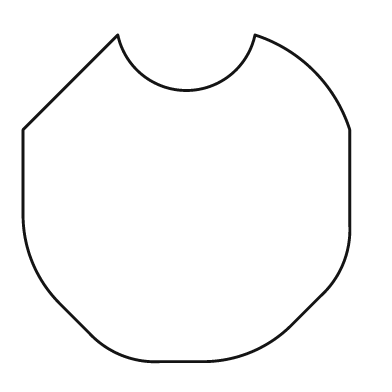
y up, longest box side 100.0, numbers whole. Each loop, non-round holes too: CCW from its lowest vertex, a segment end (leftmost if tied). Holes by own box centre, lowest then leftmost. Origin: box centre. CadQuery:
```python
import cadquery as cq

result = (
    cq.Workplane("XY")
    .moveTo(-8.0, -50.0)
    .lineTo(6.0, -50.0)
    .threePointArc((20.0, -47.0), (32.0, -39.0))
    .lineTo(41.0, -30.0)
    .threePointArc((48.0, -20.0), (50.0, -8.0))
    .lineTo(50.0, 21.0)
    .threePointArc((39.0, 39.0), (21.0, 50.0))
    .threePointArc((0.0, 33.0), (-21.0, 50.0))
    .lineTo(-50.0, 21.0)
    .lineTo(-50.0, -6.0)
    .threePointArc((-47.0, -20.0), (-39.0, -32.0))
    .lineTo(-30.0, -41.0)
    .threePointArc((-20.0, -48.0), (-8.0, -50.0))
    .close()
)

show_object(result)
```